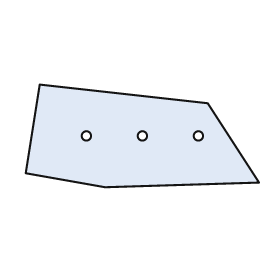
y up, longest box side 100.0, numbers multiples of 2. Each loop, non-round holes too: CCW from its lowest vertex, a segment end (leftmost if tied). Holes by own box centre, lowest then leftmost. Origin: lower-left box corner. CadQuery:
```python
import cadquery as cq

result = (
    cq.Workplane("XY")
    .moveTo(34.0, 0.0)
    .lineTo(100.0, 2.0)
    .lineTo(78.0, 36.0)
    .lineTo(6.0, 44.0)
    .lineTo(0.0, 6.0)
    .close()
    .moveTo(26.0, 22.0)
    .circle(2.0)
    .moveTo(50.0, 22.0)
    .circle(2.0)
    .moveTo(74.0, 22.0)
    .circle(2.0)
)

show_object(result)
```